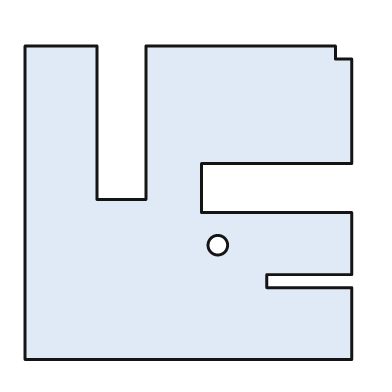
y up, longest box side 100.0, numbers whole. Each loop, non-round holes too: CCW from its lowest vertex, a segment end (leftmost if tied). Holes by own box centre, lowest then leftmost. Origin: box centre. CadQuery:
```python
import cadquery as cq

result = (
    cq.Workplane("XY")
    .moveTo(-50.0, -48.0)
    .lineTo(50.0, -48.0)
    .lineTo(50.0, -26.0)
    .lineTo(24.0, -26.0)
    .lineTo(24.0, -22.0)
    .lineTo(50.0, -22.0)
    .lineTo(50.0, -3.0)
    .lineTo(4.0, -3.0)
    .lineTo(4.0, 12.0)
    .lineTo(50.0, 12.0)
    .lineTo(50.0, 44.0)
    .lineTo(45.0, 44.0)
    .lineTo(45.0, 48.0)
    .lineTo(-13.0, 48.0)
    .lineTo(-13.0, 1.0)
    .lineTo(-28.0, 1.0)
    .lineTo(-28.0, 48.0)
    .lineTo(-50.0, 48.0)
    .close()
    .moveTo(9.0, -13.0)
    .circle(3.0)
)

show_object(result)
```